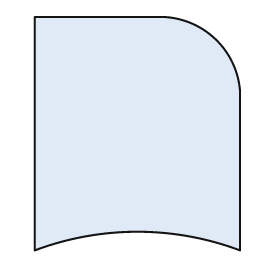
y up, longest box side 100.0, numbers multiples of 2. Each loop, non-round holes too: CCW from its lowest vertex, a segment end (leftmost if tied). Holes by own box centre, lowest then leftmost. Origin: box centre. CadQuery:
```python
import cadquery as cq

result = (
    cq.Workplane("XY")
    .moveTo(-44.0, -50.0)
    .threePointArc((0.0, -42.0), (44.0, -50.0))
    .lineTo(44.0, 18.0)
    .threePointArc((34.0, 40.0), (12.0, 50.0))
    .lineTo(-44.0, 50.0)
    .close()
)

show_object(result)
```